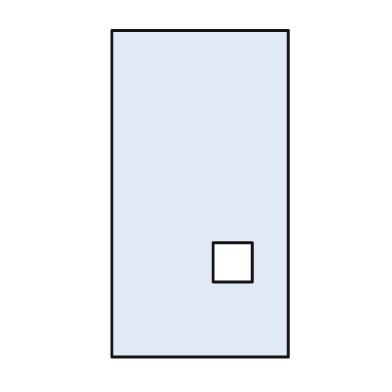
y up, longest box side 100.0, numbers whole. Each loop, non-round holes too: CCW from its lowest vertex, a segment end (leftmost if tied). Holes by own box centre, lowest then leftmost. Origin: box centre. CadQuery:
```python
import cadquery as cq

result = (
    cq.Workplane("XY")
    .moveTo(-27.0, -50.0)
    .lineTo(27.0, -50.0)
    .lineTo(27.0, 50.0)
    .lineTo(-27.0, 50.0)
    .close()
    .moveTo(4.0, -27.0)
    .lineTo(16.0, -27.0)
    .lineTo(16.0, -15.0)
    .lineTo(4.0, -15.0)
    .close()
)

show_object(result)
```